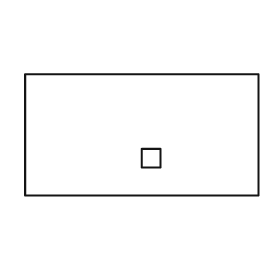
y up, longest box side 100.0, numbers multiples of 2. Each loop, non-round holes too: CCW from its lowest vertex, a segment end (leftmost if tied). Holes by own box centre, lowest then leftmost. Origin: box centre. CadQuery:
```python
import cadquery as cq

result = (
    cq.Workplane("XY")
    .moveTo(-50.0, -26.0)
    .lineTo(50.0, -26.0)
    .lineTo(50.0, 26.0)
    .lineTo(-50.0, 26.0)
    .close()
    .moveTo(0.0, -14.0)
    .lineTo(8.0, -14.0)
    .lineTo(8.0, -6.0)
    .lineTo(0.0, -6.0)
    .close()
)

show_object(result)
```